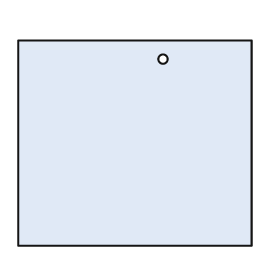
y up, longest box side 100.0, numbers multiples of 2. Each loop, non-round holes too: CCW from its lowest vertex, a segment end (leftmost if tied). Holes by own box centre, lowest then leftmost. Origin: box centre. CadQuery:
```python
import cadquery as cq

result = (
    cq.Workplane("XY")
    .moveTo(-50.0, -44.0)
    .lineTo(50.0, -44.0)
    .lineTo(50.0, 44.0)
    .lineTo(-50.0, 44.0)
    .close()
    .moveTo(12.0, 36.0)
    .circle(2.0)
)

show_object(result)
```